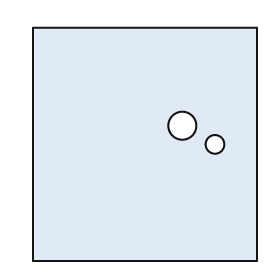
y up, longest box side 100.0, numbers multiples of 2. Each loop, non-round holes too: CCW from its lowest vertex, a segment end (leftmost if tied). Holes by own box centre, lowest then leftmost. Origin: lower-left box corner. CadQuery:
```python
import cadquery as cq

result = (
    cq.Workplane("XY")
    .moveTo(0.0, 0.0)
    .lineTo(96.0, 0.0)
    .lineTo(96.0, 100.0)
    .lineTo(0.0, 100.0)
    .close()
    .moveTo(78.0, 50.0)
    .circle(4.0)
    .moveTo(64.0, 58.0)
    .circle(6.0)
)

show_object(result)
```